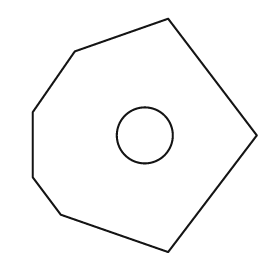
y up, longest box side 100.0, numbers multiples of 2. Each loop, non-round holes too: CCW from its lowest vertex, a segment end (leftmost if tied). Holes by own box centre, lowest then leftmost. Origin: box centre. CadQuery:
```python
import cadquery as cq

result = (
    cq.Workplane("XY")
    .moveTo(10.0, -50.0)
    .lineTo(48.0, 0.0)
    .lineTo(10.0, 50.0)
    .lineTo(-30.0, 36.0)
    .lineTo(-48.0, 10.0)
    .lineTo(-48.0, -18.0)
    .lineTo(-36.0, -34.0)
    .close()
    .moveTo(0.0, 0.0)
    .circle(12.0)
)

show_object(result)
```